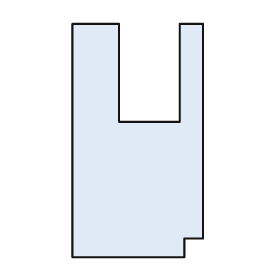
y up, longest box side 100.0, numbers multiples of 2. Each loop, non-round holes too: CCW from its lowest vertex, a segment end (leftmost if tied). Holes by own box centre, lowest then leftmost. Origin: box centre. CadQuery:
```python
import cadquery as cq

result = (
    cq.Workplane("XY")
    .moveTo(-28.0, -50.0)
    .lineTo(20.0, -50.0)
    .lineTo(20.0, -42.0)
    .lineTo(28.0, -42.0)
    .lineTo(28.0, 50.0)
    .lineTo(18.0, 50.0)
    .lineTo(18.0, 8.0)
    .lineTo(-8.0, 8.0)
    .lineTo(-8.0, 50.0)
    .lineTo(-28.0, 50.0)
    .close()
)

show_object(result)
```